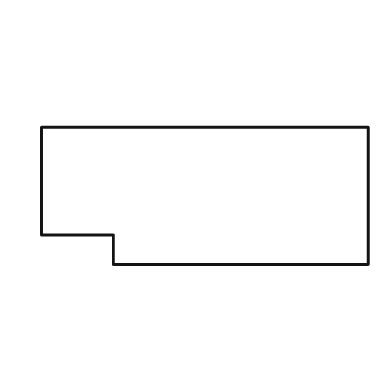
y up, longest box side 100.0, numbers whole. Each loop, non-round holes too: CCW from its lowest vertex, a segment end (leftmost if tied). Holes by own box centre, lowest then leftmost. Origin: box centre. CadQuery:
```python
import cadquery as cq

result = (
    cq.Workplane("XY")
    .moveTo(-28.0, -21.0)
    .lineTo(50.0, -21.0)
    .lineTo(50.0, 21.0)
    .lineTo(-50.0, 21.0)
    .lineTo(-50.0, -12.0)
    .lineTo(-28.0, -12.0)
    .close()
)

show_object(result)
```